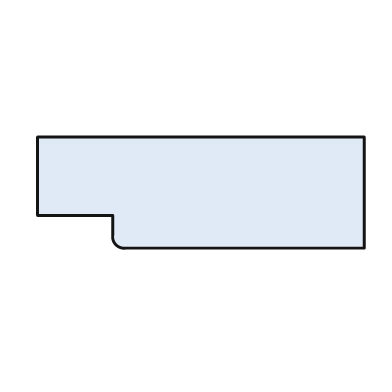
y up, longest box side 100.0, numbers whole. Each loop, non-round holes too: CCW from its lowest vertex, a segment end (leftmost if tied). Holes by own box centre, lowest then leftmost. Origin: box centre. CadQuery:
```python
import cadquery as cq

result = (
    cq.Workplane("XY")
    .moveTo(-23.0, -17.0)
    .lineTo(50.0, -17.0)
    .lineTo(50.0, 17.0)
    .lineTo(-50.0, 17.0)
    .lineTo(-50.0, -7.0)
    .lineTo(-27.0, -7.0)
    .lineTo(-27.0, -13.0)
    .threePointArc((-26.0, -16.0), (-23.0, -17.0))
    .close()
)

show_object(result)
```